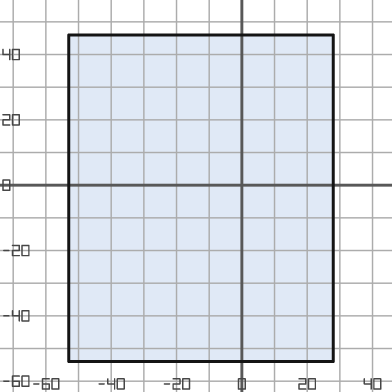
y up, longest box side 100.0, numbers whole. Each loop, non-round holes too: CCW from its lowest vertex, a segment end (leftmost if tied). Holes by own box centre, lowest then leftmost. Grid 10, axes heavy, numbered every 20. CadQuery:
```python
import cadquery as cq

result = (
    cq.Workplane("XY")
    .moveTo(-53.0, -54.0)
    .lineTo(28.0, -54.0)
    .lineTo(28.0, 46.0)
    .lineTo(-53.0, 46.0)
    .close()
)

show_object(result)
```